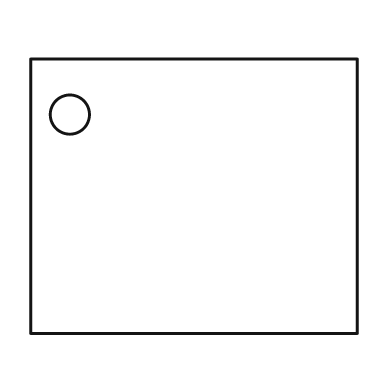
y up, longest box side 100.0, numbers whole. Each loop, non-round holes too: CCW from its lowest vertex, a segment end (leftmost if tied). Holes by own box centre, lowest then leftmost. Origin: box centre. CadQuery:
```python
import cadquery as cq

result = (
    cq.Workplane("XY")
    .moveTo(-50.0, -42.0)
    .lineTo(50.0, -42.0)
    .lineTo(50.0, 42.0)
    .lineTo(-50.0, 42.0)
    .close()
    .moveTo(-38.0, 25.0)
    .circle(6.0)
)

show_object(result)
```